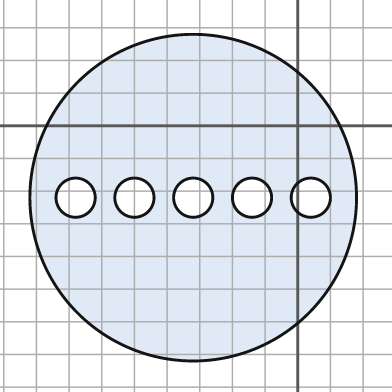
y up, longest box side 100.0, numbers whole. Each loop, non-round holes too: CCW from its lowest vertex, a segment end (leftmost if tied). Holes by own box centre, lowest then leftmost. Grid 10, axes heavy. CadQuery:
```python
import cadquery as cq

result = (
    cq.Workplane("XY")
    .moveTo(-32.0, -22.0)
    .circle(50.0)
    .moveTo(-68.0, -22.0)
    .circle(6.0)
    .moveTo(-50.0, -22.0)
    .circle(6.0)
    .moveTo(-32.0, -22.0)
    .circle(6.0)
    .moveTo(-14.0, -22.0)
    .circle(6.0)
    .moveTo(4.0, -22.0)
    .circle(6.0)
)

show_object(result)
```